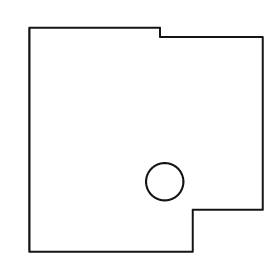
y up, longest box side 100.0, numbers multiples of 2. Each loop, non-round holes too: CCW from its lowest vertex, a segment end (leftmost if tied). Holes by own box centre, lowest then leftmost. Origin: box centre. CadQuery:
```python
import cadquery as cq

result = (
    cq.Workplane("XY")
    .moveTo(-50.0, -48.0)
    .lineTo(20.0, -48.0)
    .lineTo(20.0, -30.0)
    .lineTo(50.0, -30.0)
    .lineTo(50.0, 44.0)
    .lineTo(6.0, 44.0)
    .lineTo(6.0, 48.0)
    .lineTo(-50.0, 48.0)
    .close()
    .moveTo(8.0, -18.0)
    .circle(8.0)
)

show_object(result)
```